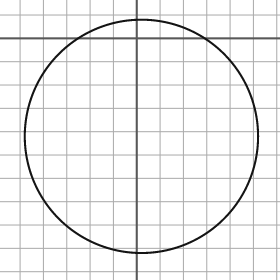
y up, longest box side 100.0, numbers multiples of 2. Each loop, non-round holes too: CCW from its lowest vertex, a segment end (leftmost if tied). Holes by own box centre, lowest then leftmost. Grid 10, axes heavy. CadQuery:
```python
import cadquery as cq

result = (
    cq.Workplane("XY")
    .moveTo(2.0, -42.0)
    .circle(50.0)
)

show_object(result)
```